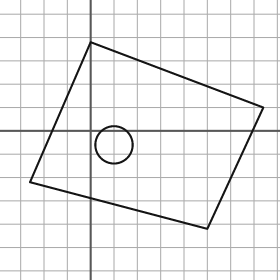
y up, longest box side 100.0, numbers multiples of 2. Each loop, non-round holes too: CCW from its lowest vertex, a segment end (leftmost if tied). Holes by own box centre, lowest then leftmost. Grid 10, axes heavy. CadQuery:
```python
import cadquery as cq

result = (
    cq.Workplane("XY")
    .moveTo(50.0, -42.0)
    .lineTo(74.0, 10.0)
    .lineTo(0.0, 38.0)
    .lineTo(-26.0, -22.0)
    .close()
    .moveTo(10.0, -6.0)
    .circle(8.0)
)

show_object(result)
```